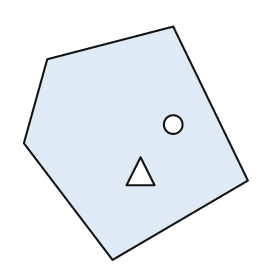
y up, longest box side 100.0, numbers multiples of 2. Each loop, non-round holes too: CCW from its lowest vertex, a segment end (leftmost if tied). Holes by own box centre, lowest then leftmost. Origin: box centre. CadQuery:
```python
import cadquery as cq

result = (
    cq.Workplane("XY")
    .moveTo(-10.0, -50.0)
    .lineTo(48.0, -16.0)
    .lineTo(16.0, 50.0)
    .lineTo(-38.0, 36.0)
    .lineTo(-48.0, 0.0)
    .close()
    .moveTo(-4.0, -18.0)
    .lineTo(8.0, -18.0)
    .lineTo(2.0, -6.0)
    .close()
    .moveTo(16.0, 8.0)
    .circle(4.0)
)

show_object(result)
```